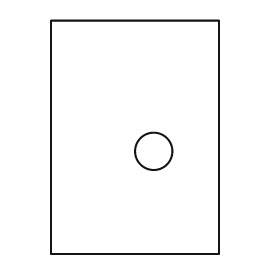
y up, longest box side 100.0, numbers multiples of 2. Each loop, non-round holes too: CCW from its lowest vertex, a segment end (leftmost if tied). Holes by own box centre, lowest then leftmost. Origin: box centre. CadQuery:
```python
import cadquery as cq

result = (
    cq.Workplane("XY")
    .moveTo(-36.0, -50.0)
    .lineTo(36.0, -50.0)
    .lineTo(36.0, 50.0)
    .lineTo(-36.0, 50.0)
    .close()
    .moveTo(8.0, -6.0)
    .circle(8.0)
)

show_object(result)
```